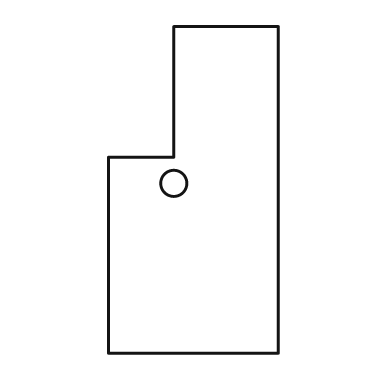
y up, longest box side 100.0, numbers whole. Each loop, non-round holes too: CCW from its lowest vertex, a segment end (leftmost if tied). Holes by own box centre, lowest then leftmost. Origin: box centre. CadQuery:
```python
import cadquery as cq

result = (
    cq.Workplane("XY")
    .moveTo(-26.0, -50.0)
    .lineTo(26.0, -50.0)
    .lineTo(26.0, 50.0)
    .lineTo(-6.0, 50.0)
    .lineTo(-6.0, 10.0)
    .lineTo(-26.0, 10.0)
    .close()
    .moveTo(-6.0, 2.0)
    .circle(4.0)
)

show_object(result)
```